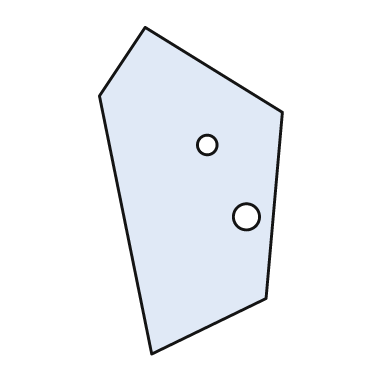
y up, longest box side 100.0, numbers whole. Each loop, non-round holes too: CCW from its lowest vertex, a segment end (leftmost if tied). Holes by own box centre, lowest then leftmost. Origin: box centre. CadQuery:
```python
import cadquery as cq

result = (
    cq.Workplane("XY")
    .moveTo(-12.0, -50.0)
    .lineTo(23.0, -33.0)
    .lineTo(28.0, 24.0)
    .lineTo(-14.0, 50.0)
    .lineTo(-28.0, 29.0)
    .close()
    .moveTo(17.0, -8.0)
    .circle(4.0)
    .moveTo(5.0, 14.0)
    .circle(3.0)
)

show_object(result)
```